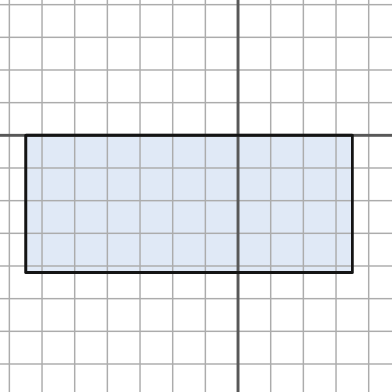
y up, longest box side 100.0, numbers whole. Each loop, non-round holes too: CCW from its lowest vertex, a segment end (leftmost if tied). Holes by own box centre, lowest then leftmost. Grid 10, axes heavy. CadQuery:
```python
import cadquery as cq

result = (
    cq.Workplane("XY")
    .moveTo(-65.0, -42.0)
    .lineTo(35.0, -42.0)
    .lineTo(35.0, 0.0)
    .lineTo(-65.0, 0.0)
    .close()
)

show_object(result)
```